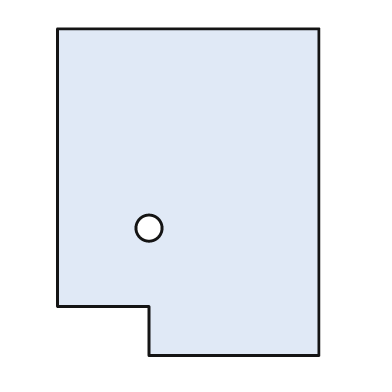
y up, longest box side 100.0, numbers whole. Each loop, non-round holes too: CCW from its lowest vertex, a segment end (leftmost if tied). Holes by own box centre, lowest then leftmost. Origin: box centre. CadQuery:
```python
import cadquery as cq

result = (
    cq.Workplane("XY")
    .moveTo(-12.0, -50.0)
    .lineTo(40.0, -50.0)
    .lineTo(40.0, 50.0)
    .lineTo(-40.0, 50.0)
    .lineTo(-40.0, -35.0)
    .lineTo(-12.0, -35.0)
    .close()
    .moveTo(-12.0, -11.0)
    .circle(4.0)
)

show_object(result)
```